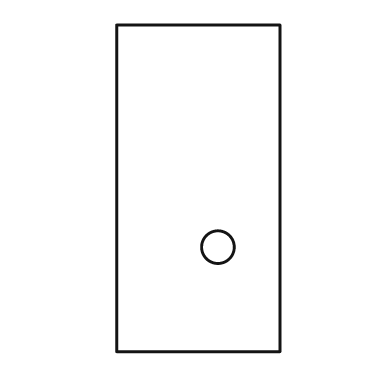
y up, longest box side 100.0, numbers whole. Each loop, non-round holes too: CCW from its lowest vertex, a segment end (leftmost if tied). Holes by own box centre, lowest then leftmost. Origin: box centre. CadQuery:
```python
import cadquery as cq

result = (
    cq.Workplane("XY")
    .moveTo(-25.0, -50.0)
    .lineTo(25.0, -50.0)
    .lineTo(25.0, 50.0)
    .lineTo(-25.0, 50.0)
    .close()
    .moveTo(6.0, -18.0)
    .circle(5.0)
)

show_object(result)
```